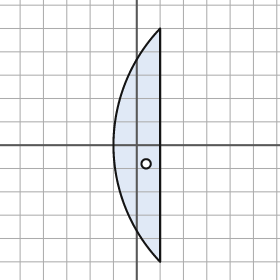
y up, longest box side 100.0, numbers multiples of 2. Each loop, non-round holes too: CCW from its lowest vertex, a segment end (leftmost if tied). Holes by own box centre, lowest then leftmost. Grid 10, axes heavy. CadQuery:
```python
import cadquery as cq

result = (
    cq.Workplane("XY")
    .moveTo(10.0, -50.0)
    .lineTo(10.0, 50.0)
    .threePointArc((-10.0, 0.0), (10.0, -50.0))
    .close()
    .moveTo(4.0, -8.0)
    .circle(2.0)
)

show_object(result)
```